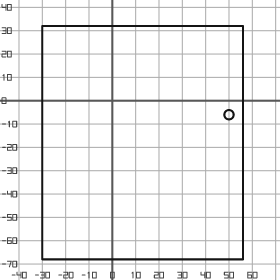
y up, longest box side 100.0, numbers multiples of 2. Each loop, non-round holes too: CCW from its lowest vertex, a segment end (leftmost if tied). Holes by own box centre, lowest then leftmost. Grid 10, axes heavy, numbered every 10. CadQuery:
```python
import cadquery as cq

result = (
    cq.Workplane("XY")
    .moveTo(-30.0, -68.0)
    .lineTo(56.0, -68.0)
    .lineTo(56.0, 32.0)
    .lineTo(-30.0, 32.0)
    .close()
    .moveTo(50.0, -6.0)
    .circle(2.0)
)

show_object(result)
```